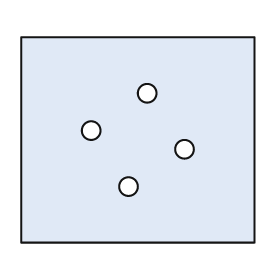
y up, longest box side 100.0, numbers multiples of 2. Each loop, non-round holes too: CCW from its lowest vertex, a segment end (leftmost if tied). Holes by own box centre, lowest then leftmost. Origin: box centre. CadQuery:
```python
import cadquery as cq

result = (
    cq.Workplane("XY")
    .moveTo(-50.0, -44.0)
    .lineTo(50.0, -44.0)
    .lineTo(50.0, 44.0)
    .lineTo(-50.0, 44.0)
    .close()
    .moveTo(-4.0, -20.0)
    .circle(4.0)
    .moveTo(20.0, -4.0)
    .circle(4.0)
    .moveTo(-20.0, 4.0)
    .circle(4.0)
    .moveTo(4.0, 20.0)
    .circle(4.0)
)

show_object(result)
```